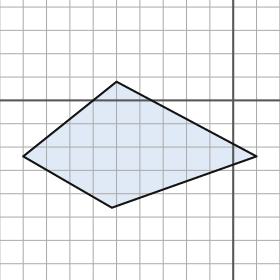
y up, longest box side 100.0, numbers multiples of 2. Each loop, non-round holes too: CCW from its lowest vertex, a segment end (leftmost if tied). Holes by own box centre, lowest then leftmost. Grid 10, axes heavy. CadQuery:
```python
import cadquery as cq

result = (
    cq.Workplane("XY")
    .moveTo(-52.0, -46.0)
    .lineTo(10.0, -24.0)
    .lineTo(-50.0, 8.0)
    .lineTo(-90.0, -24.0)
    .close()
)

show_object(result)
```